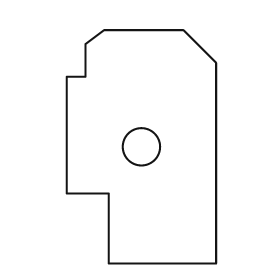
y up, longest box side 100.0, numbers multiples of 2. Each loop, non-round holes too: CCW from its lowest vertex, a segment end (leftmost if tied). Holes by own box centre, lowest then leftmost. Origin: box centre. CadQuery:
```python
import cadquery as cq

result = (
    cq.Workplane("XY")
    .moveTo(-14.0, -50.0)
    .lineTo(32.0, -50.0)
    .lineTo(32.0, 36.0)
    .lineTo(18.0, 50.0)
    .lineTo(-16.0, 50.0)
    .lineTo(-24.0, 44.0)
    .lineTo(-24.0, 30.0)
    .lineTo(-32.0, 30.0)
    .lineTo(-32.0, -20.0)
    .lineTo(-14.0, -20.0)
    .close()
    .moveTo(0.0, 0.0)
    .circle(8.0)
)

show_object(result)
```